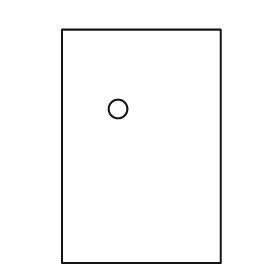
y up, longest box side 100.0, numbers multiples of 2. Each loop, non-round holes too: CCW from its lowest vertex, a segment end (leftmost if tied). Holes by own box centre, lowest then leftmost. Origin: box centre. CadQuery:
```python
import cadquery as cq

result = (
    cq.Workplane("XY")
    .moveTo(-34.0, -50.0)
    .lineTo(34.0, -50.0)
    .lineTo(34.0, 50.0)
    .lineTo(-34.0, 50.0)
    .close()
    .moveTo(-10.0, 16.0)
    .circle(4.0)
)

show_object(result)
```